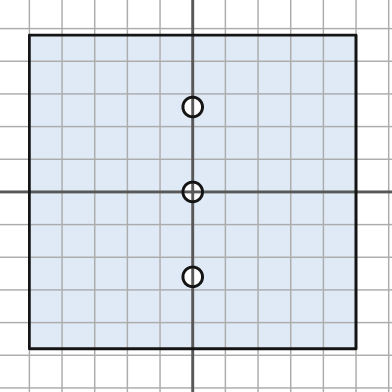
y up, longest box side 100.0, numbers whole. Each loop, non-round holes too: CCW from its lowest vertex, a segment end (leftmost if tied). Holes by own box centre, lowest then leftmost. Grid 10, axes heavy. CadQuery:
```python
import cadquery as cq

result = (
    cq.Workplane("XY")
    .moveTo(-50.0, -48.0)
    .lineTo(50.0, -48.0)
    .lineTo(50.0, 48.0)
    .lineTo(-50.0, 48.0)
    .close()
    .moveTo(0.0, -26.0)
    .circle(3.0)
    .moveTo(0.0, 0.0)
    .circle(3.0)
    .moveTo(0.0, 26.0)
    .circle(3.0)
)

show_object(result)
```